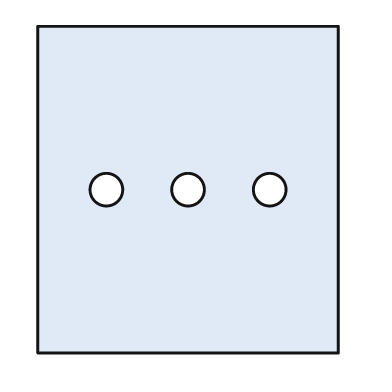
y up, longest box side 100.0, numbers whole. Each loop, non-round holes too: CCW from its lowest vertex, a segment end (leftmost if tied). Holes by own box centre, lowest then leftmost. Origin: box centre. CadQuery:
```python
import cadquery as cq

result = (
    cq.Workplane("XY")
    .moveTo(-46.0, -50.0)
    .lineTo(46.0, -50.0)
    .lineTo(46.0, 50.0)
    .lineTo(-46.0, 50.0)
    .close()
    .moveTo(-25.0, 0.0)
    .circle(5.0)
    .moveTo(0.0, 0.0)
    .circle(5.0)
    .moveTo(25.0, 0.0)
    .circle(5.0)
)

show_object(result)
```